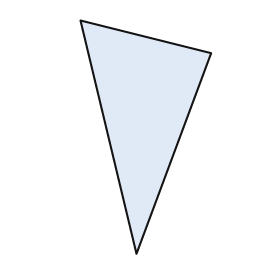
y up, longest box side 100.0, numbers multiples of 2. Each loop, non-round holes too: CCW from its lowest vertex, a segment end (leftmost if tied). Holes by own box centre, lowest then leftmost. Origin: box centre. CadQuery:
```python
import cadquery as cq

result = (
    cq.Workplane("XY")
    .moveTo(-4.0, -50.0)
    .lineTo(28.0, 36.0)
    .lineTo(-28.0, 50.0)
    .close()
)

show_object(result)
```